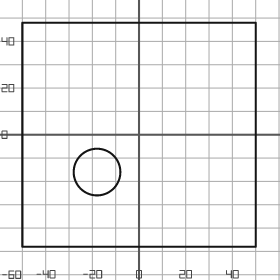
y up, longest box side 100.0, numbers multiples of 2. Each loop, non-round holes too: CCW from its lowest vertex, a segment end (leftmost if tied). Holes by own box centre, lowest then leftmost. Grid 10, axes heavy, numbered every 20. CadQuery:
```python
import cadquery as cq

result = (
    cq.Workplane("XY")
    .moveTo(-50.0, -48.0)
    .lineTo(50.0, -48.0)
    .lineTo(50.0, 48.0)
    .lineTo(-50.0, 48.0)
    .close()
    .moveTo(-18.0, -16.0)
    .circle(10.0)
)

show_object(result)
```